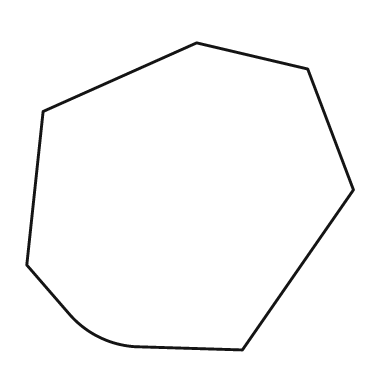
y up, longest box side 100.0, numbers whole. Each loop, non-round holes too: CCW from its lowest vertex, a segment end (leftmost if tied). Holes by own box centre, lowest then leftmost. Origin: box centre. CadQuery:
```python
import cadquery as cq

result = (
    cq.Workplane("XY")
    .moveTo(16.0, -47.0)
    .lineTo(50.0, 2.0)
    .lineTo(36.0, 39.0)
    .lineTo(2.0, 47.0)
    .lineTo(-45.0, 26.0)
    .lineTo(-50.0, -21.0)
    .lineTo(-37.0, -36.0)
    .threePointArc((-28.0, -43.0), (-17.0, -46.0))
    .close()
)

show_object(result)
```